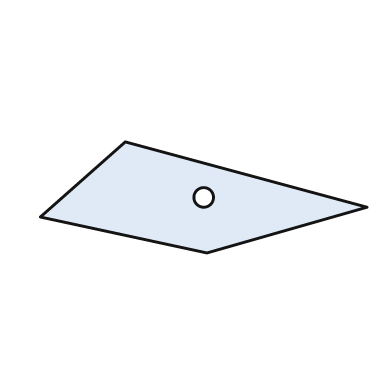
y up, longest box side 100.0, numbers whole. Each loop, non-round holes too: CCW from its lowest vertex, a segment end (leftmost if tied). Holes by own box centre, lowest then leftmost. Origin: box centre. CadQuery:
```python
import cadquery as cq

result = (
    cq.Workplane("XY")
    .moveTo(1.0, -17.0)
    .lineTo(50.0, -3.0)
    .lineTo(-24.0, 17.0)
    .lineTo(-50.0, -6.0)
    .close()
    .moveTo(0.0, 0.0)
    .circle(3.0)
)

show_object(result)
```